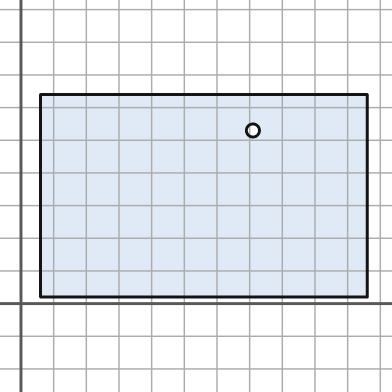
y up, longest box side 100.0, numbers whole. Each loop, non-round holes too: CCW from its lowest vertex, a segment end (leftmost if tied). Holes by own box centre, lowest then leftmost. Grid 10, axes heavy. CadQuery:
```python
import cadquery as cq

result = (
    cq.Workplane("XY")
    .moveTo(6.0, 2.0)
    .lineTo(106.0, 2.0)
    .lineTo(106.0, 64.0)
    .lineTo(6.0, 64.0)
    .close()
    .moveTo(71.0, 53.0)
    .circle(2.0)
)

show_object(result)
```